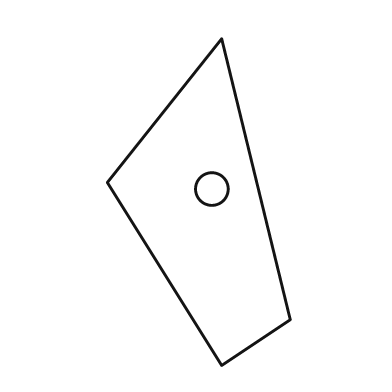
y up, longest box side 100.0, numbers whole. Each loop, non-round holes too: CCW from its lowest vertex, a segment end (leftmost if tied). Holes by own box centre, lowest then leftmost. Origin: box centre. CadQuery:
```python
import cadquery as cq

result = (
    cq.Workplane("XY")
    .moveTo(7.0, -50.0)
    .lineTo(28.0, -36.0)
    .lineTo(7.0, 50.0)
    .lineTo(-28.0, 6.0)
    .close()
    .moveTo(4.0, 4.0)
    .circle(5.0)
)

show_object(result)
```